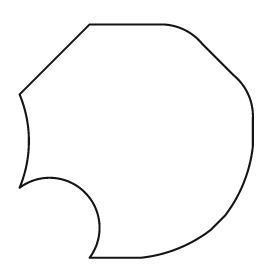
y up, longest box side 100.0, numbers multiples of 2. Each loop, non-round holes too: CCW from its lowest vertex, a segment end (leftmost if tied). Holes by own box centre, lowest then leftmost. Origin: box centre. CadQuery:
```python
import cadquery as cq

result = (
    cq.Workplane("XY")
    .moveTo(-20.0, -50.0)
    .lineTo(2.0, -50.0)
    .threePointArc((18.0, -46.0), (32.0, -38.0))
    .lineTo(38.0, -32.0)
    .threePointArc((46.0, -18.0), (50.0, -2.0))
    .lineTo(50.0, 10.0)
    .threePointArc((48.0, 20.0), (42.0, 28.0))
    .lineTo(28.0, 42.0)
    .threePointArc((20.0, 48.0), (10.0, 50.0))
    .lineTo(-20.0, 50.0)
    .lineTo(-50.0, 20.0)
    .threePointArc((-46.0, 0.0), (-50.0, -20.0))
    .threePointArc((-22.0, -22.0), (-20.0, -50.0))
    .close()
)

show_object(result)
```